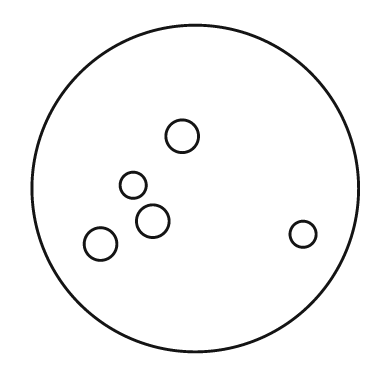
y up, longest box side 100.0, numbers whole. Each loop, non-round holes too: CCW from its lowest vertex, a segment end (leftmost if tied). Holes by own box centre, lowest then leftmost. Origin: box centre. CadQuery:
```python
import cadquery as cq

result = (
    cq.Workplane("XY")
    .moveTo(0.0, 0.0)
    .circle(50.0)
    .moveTo(-29.0, -17.0)
    .circle(5.0)
    .moveTo(33.0, -14.0)
    .circle(4.0)
    .moveTo(-13.0, -10.0)
    .circle(5.0)
    .moveTo(-19.0, 1.0)
    .circle(4.0)
    .moveTo(-4.0, 16.0)
    .circle(5.0)
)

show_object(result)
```